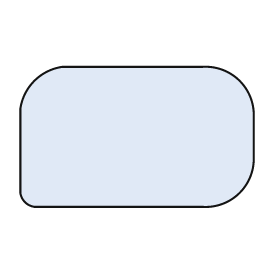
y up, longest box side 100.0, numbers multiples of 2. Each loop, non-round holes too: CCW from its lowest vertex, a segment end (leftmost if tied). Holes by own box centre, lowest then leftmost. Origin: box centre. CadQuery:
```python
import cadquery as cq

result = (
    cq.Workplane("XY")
    .moveTo(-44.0, -30.0)
    .lineTo(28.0, -30.0)
    .threePointArc((44.0, -24.0), (50.0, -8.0))
    .lineTo(50.0, 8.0)
    .threePointArc((44.0, 24.0), (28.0, 30.0))
    .lineTo(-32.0, 30.0)
    .threePointArc((-44.0, 24.0), (-50.0, 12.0))
    .lineTo(-50.0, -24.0)
    .threePointArc((-48.0, -28.0), (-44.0, -30.0))
    .close()
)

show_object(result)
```